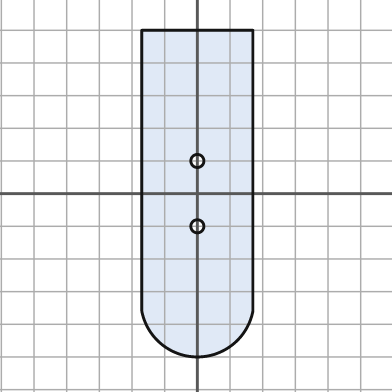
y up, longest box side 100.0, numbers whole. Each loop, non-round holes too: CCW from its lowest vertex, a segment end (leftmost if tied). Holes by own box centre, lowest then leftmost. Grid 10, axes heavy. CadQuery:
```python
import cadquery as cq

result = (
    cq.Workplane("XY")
    .moveTo(-17.0, -36.0)
    .threePointArc((0.0, -50.0), (17.0, -36.0))
    .lineTo(17.0, 50.0)
    .lineTo(-17.0, 50.0)
    .close()
    .moveTo(0.0, -10.0)
    .circle(2.0)
    .moveTo(0.0, 10.0)
    .circle(2.0)
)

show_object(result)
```